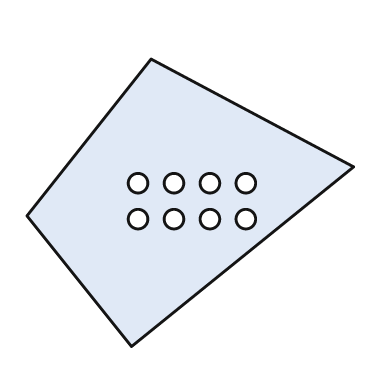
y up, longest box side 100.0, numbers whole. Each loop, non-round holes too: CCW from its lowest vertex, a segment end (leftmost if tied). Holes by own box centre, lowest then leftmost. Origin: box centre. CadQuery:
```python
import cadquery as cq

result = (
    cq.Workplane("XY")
    .moveTo(-18.0, -44.0)
    .lineTo(50.0, 11.0)
    .lineTo(-12.0, 44.0)
    .lineTo(-50.0, -4.0)
    .close()
    .moveTo(-16.0, -5.0)
    .circle(3.0)
    .moveTo(-5.0, -5.0)
    .circle(3.0)
    .moveTo(6.0, -5.0)
    .circle(3.0)
    .moveTo(17.0, -5.0)
    .circle(3.0)
    .moveTo(-16.0, 6.0)
    .circle(3.0)
    .moveTo(-5.0, 6.0)
    .circle(3.0)
    .moveTo(6.0, 6.0)
    .circle(3.0)
    .moveTo(17.0, 6.0)
    .circle(3.0)
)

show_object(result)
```